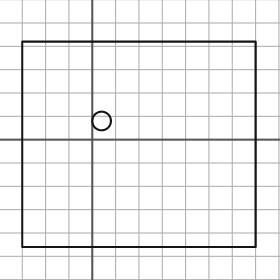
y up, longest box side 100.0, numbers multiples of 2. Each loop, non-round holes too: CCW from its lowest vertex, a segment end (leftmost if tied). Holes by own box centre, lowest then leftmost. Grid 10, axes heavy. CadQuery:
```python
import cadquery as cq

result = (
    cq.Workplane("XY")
    .moveTo(-30.0, -46.0)
    .lineTo(70.0, -46.0)
    .lineTo(70.0, 42.0)
    .lineTo(-30.0, 42.0)
    .close()
    .moveTo(4.0, 8.0)
    .circle(4.0)
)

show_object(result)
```